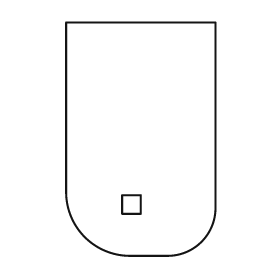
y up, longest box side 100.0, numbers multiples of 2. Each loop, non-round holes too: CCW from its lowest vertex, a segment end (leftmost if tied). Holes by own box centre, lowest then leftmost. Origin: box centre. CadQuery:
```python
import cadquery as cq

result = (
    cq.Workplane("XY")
    .moveTo(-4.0, -50.0)
    .lineTo(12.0, -50.0)
    .threePointArc((26.0, -44.0), (32.0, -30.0))
    .lineTo(32.0, 50.0)
    .lineTo(-32.0, 50.0)
    .lineTo(-32.0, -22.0)
    .threePointArc((-24.0, -42.0), (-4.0, -50.0))
    .close()
    .moveTo(-8.0, -32.0)
    .lineTo(0.0, -32.0)
    .lineTo(0.0, -24.0)
    .lineTo(-8.0, -24.0)
    .close()
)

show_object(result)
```